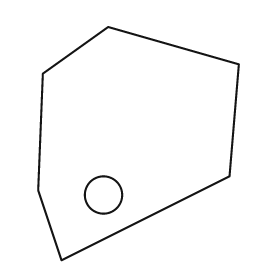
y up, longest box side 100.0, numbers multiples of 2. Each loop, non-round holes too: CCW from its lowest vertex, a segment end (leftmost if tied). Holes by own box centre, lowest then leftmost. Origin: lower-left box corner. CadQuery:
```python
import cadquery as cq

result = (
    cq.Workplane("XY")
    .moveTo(10.0, 0.0)
    .lineTo(82.0, 36.0)
    .lineTo(86.0, 84.0)
    .lineTo(30.0, 100.0)
    .lineTo(2.0, 80.0)
    .lineTo(0.0, 30.0)
    .close()
    .moveTo(28.0, 28.0)
    .circle(8.0)
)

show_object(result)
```